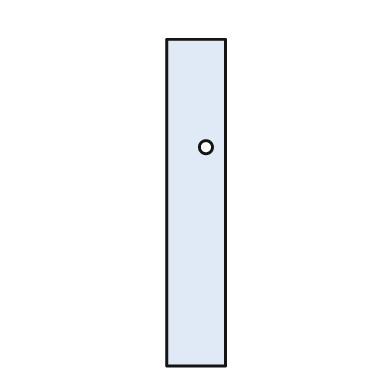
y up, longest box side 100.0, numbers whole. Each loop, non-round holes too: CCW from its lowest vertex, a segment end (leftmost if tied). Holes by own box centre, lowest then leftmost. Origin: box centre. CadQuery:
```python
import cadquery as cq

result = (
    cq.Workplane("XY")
    .moveTo(-9.0, -50.0)
    .lineTo(9.0, -50.0)
    .lineTo(9.0, 50.0)
    .lineTo(-9.0, 50.0)
    .close()
    .moveTo(3.0, 17.0)
    .circle(2.0)
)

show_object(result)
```